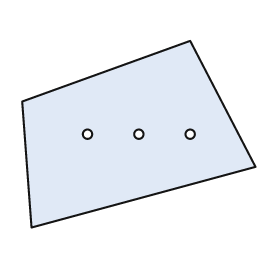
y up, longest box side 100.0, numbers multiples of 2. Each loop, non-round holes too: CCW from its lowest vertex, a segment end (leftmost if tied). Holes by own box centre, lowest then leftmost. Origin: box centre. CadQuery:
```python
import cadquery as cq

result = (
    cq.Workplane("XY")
    .moveTo(-46.0, -40.0)
    .lineTo(50.0, -14.0)
    .lineTo(22.0, 40.0)
    .lineTo(-50.0, 14.0)
    .close()
    .moveTo(-22.0, 0.0)
    .circle(2.0)
    .moveTo(0.0, 0.0)
    .circle(2.0)
    .moveTo(22.0, 0.0)
    .circle(2.0)
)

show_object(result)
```